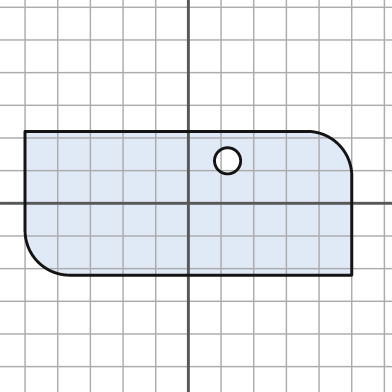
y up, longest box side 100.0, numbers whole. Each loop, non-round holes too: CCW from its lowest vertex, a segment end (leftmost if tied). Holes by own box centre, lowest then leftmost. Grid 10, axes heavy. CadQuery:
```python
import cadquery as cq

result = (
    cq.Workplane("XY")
    .moveTo(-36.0, -22.0)
    .lineTo(50.0, -22.0)
    .lineTo(50.0, 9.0)
    .threePointArc((46.0, 18.0), (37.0, 22.0))
    .lineTo(-50.0, 22.0)
    .lineTo(-50.0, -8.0)
    .threePointArc((-46.0, -18.0), (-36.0, -22.0))
    .close()
    .moveTo(12.0, 13.0)
    .circle(4.0)
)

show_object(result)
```